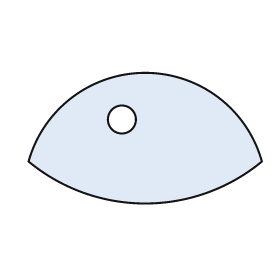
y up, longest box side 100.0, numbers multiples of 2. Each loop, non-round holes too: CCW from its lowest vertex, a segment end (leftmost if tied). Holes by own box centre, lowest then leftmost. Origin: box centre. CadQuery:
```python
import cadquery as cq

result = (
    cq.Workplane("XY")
    .moveTo(-50.0, -10.0)
    .threePointArc((0.0, -28.0), (50.0, -10.0))
    .threePointArc((0.0, 28.0), (-50.0, -10.0))
    .close()
    .moveTo(-10.0, 8.0)
    .circle(6.0)
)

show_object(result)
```